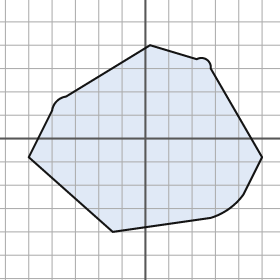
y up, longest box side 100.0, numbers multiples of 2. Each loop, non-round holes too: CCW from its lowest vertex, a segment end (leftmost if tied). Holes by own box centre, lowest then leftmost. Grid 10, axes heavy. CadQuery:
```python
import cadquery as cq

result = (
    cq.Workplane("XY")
    .moveTo(-14.0, -40.0)
    .lineTo(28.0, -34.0)
    .threePointArc((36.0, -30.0), (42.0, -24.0))
    .lineTo(50.0, -8.0)
    .lineTo(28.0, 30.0)
    .threePointArc((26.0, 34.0), (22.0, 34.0))
    .lineTo(2.0, 40.0)
    .lineTo(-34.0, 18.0)
    .threePointArc((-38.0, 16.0), (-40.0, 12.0))
    .lineTo(-50.0, -8.0)
    .close()
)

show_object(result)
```